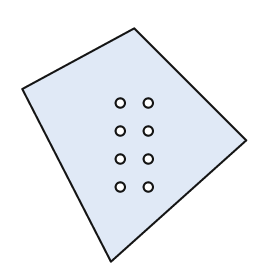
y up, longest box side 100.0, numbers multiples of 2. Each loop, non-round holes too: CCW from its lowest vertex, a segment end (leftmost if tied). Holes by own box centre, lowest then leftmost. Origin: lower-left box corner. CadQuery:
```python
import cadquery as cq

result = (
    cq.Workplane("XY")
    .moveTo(38.0, 0.0)
    .lineTo(96.0, 52.0)
    .lineTo(48.0, 100.0)
    .lineTo(0.0, 74.0)
    .close()
    .moveTo(42.0, 32.0)
    .circle(2.0)
    .moveTo(54.0, 32.0)
    .circle(2.0)
    .moveTo(42.0, 44.0)
    .circle(2.0)
    .moveTo(54.0, 44.0)
    .circle(2.0)
    .moveTo(42.0, 56.0)
    .circle(2.0)
    .moveTo(54.0, 56.0)
    .circle(2.0)
    .moveTo(42.0, 68.0)
    .circle(2.0)
    .moveTo(54.0, 68.0)
    .circle(2.0)
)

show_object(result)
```